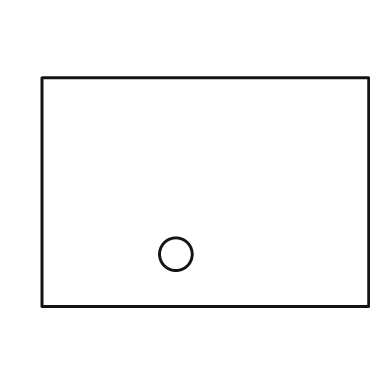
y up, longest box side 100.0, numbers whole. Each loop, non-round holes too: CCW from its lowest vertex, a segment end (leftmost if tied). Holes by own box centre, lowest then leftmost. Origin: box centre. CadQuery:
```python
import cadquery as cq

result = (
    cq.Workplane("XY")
    .moveTo(-50.0, -35.0)
    .lineTo(50.0, -35.0)
    .lineTo(50.0, 35.0)
    .lineTo(-50.0, 35.0)
    .close()
    .moveTo(-9.0, -19.0)
    .circle(5.0)
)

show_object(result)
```